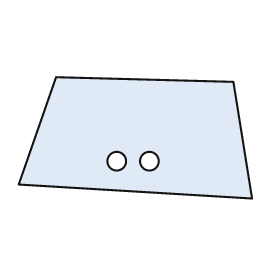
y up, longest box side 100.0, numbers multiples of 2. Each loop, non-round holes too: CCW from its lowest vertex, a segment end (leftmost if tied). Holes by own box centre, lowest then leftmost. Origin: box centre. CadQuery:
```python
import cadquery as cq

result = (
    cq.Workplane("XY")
    .moveTo(50.0, -26.0)
    .lineTo(42.0, 24.0)
    .lineTo(-34.0, 26.0)
    .lineTo(-50.0, -20.0)
    .close()
    .moveTo(-8.0, -10.0)
    .circle(4.0)
    .moveTo(6.0, -10.0)
    .circle(4.0)
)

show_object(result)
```